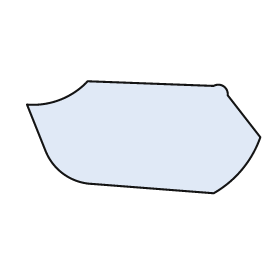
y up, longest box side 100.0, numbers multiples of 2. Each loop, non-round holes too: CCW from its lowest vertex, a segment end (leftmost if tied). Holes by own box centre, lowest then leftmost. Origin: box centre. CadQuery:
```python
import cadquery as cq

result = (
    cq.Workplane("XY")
    .moveTo(30.0, -24.0)
    .threePointArc((42.0, -14.0), (50.0, 0.0))
    .lineTo(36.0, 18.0)
    .threePointArc((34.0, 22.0), (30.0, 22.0))
    .lineTo(-24.0, 24.0)
    .threePointArc((-36.0, 16.0), (-50.0, 14.0))
    .lineTo(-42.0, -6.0)
    .threePointArc((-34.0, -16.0), (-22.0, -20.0))
    .close()
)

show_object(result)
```